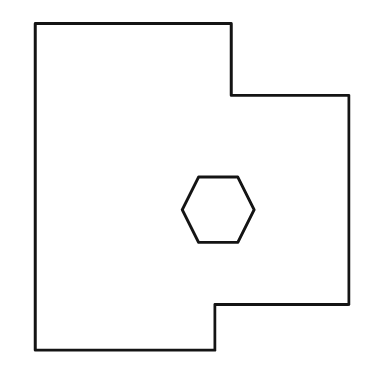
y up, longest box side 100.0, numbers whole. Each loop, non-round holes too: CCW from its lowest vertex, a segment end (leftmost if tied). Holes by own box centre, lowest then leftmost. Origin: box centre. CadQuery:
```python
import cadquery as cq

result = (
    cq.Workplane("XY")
    .moveTo(-48.0, -50.0)
    .lineTo(7.0, -50.0)
    .lineTo(7.0, -36.0)
    .lineTo(48.0, -36.0)
    .lineTo(48.0, 28.0)
    .lineTo(12.0, 28.0)
    .lineTo(12.0, 50.0)
    .lineTo(-48.0, 50.0)
    .close()
    .moveTo(2.0, -17.0)
    .lineTo(14.0, -17.0)
    .lineTo(19.0, -7.0)
    .lineTo(14.0, 3.0)
    .lineTo(2.0, 3.0)
    .lineTo(-3.0, -7.0)
    .close()
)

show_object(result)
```